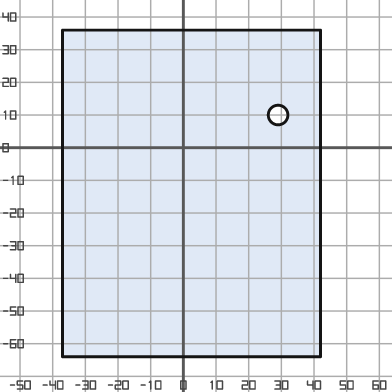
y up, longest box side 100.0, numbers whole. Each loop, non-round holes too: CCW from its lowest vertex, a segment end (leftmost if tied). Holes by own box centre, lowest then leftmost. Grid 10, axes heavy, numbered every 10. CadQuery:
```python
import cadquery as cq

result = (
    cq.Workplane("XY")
    .moveTo(-37.0, -64.0)
    .lineTo(42.0, -64.0)
    .lineTo(42.0, 36.0)
    .lineTo(-37.0, 36.0)
    .close()
    .moveTo(29.0, 10.0)
    .circle(3.0)
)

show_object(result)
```